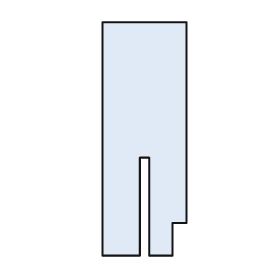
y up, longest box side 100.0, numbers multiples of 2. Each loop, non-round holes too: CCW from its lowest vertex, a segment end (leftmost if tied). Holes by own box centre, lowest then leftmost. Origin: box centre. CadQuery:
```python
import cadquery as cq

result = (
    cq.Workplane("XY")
    .moveTo(-18.0, -50.0)
    .lineTo(-2.0, -50.0)
    .lineTo(-2.0, -8.0)
    .lineTo(2.0, -8.0)
    .lineTo(2.0, -50.0)
    .lineTo(12.0, -50.0)
    .lineTo(12.0, -36.0)
    .lineTo(18.0, -36.0)
    .lineTo(18.0, 50.0)
    .lineTo(-18.0, 50.0)
    .close()
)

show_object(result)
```